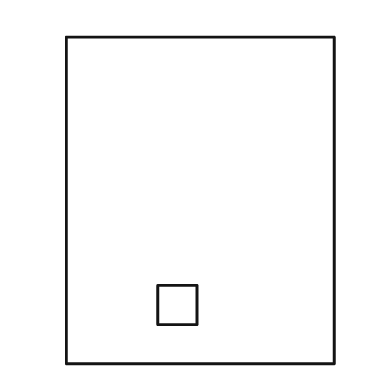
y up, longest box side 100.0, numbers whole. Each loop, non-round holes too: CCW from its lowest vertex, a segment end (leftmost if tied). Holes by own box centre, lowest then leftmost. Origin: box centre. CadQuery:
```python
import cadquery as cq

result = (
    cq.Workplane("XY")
    .moveTo(-41.0, -50.0)
    .lineTo(41.0, -50.0)
    .lineTo(41.0, 50.0)
    .lineTo(-41.0, 50.0)
    .close()
    .moveTo(-13.0, -38.0)
    .lineTo(-1.0, -38.0)
    .lineTo(-1.0, -26.0)
    .lineTo(-13.0, -26.0)
    .close()
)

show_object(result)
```